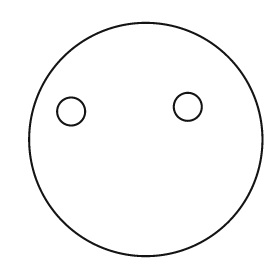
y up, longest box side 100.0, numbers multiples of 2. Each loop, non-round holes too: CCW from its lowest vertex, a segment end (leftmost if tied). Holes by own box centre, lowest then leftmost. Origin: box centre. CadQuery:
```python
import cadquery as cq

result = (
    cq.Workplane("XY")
    .moveTo(0.0, 0.0)
    .circle(50.0)
    .moveTo(-32.0, 12.0)
    .circle(6.0)
    .moveTo(18.0, 14.0)
    .circle(6.0)
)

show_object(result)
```